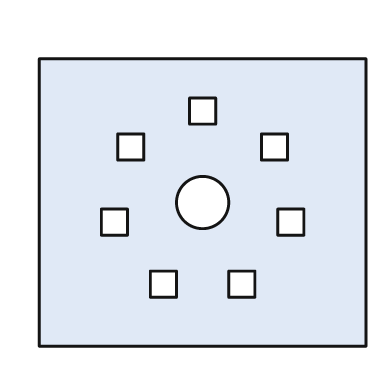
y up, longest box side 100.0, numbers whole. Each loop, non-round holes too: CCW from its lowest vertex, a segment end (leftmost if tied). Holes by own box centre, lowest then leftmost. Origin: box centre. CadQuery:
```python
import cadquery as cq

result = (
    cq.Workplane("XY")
    .moveTo(-50.0, -44.0)
    .lineTo(50.0, -44.0)
    .lineTo(50.0, 44.0)
    .lineTo(-50.0, 44.0)
    .close()
    .moveTo(-16.0, -29.0)
    .lineTo(-8.0, -29.0)
    .lineTo(-8.0, -21.0)
    .lineTo(-16.0, -21.0)
    .close()
    .moveTo(8.0, -29.0)
    .lineTo(16.0, -29.0)
    .lineTo(16.0, -21.0)
    .lineTo(8.0, -21.0)
    .close()
    .moveTo(-31.0, -10.0)
    .lineTo(-23.0, -10.0)
    .lineTo(-23.0, -2.0)
    .lineTo(-31.0, -2.0)
    .close()
    .moveTo(23.0, -10.0)
    .lineTo(31.0, -10.0)
    .lineTo(31.0, -2.0)
    .lineTo(23.0, -2.0)
    .close()
    .moveTo(0.0, 0.0)
    .circle(8.0)
    .moveTo(-26.0, 13.0)
    .lineTo(-18.0, 13.0)
    .lineTo(-18.0, 21.0)
    .lineTo(-26.0, 21.0)
    .close()
    .moveTo(18.0, 13.0)
    .lineTo(26.0, 13.0)
    .lineTo(26.0, 21.0)
    .lineTo(18.0, 21.0)
    .close()
    .moveTo(-4.0, 24.0)
    .lineTo(4.0, 24.0)
    .lineTo(4.0, 32.0)
    .lineTo(-4.0, 32.0)
    .close()
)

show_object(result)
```